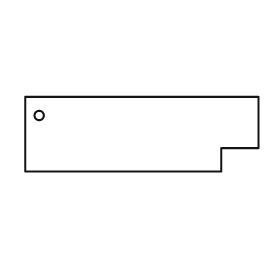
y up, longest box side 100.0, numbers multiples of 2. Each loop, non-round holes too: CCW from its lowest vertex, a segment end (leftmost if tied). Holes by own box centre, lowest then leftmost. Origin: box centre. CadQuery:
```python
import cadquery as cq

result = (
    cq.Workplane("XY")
    .moveTo(-50.0, -16.0)
    .lineTo(34.0, -16.0)
    .lineTo(34.0, -6.0)
    .lineTo(50.0, -6.0)
    .lineTo(50.0, 16.0)
    .lineTo(-50.0, 16.0)
    .close()
    .moveTo(-44.0, 8.0)
    .circle(2.0)
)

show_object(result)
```